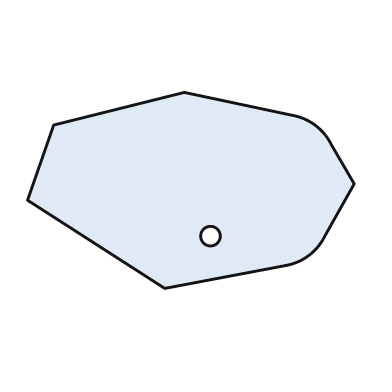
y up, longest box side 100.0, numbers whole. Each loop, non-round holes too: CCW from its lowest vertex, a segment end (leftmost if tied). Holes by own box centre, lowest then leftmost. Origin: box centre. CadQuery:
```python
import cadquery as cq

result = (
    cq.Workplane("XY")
    .moveTo(-8.0, -30.0)
    .lineTo(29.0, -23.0)
    .threePointArc((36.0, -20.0), (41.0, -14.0))
    .lineTo(50.0, 2.0)
    .lineTo(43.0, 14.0)
    .threePointArc((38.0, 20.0), (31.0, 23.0))
    .lineTo(-2.0, 30.0)
    .lineTo(-42.0, 20.0)
    .lineTo(-50.0, -3.0)
    .close()
    .moveTo(6.0, -14.0)
    .circle(3.0)
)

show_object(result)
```